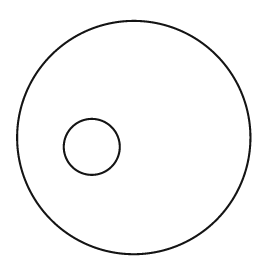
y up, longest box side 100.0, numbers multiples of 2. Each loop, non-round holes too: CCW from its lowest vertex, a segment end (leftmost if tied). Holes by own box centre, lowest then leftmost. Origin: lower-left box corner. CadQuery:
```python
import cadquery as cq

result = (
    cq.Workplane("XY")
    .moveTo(50.0, 50.0)
    .circle(50.0)
    .moveTo(32.0, 46.0)
    .circle(12.0)
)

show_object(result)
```